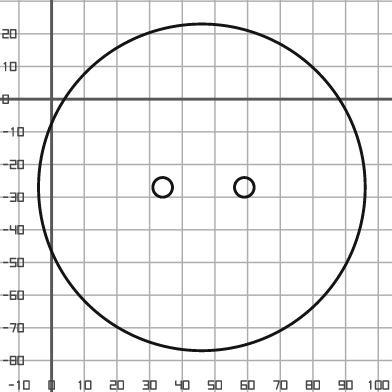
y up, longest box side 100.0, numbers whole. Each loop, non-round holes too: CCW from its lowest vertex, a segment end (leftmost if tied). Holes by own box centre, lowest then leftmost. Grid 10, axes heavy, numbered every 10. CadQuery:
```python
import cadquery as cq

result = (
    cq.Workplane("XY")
    .moveTo(46.0, -27.0)
    .circle(50.0)
    .moveTo(34.0, -27.0)
    .circle(3.0)
    .moveTo(59.0, -27.0)
    .circle(3.0)
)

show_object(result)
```